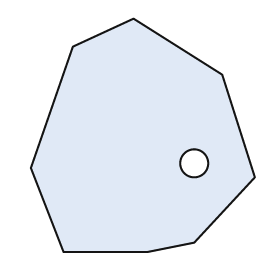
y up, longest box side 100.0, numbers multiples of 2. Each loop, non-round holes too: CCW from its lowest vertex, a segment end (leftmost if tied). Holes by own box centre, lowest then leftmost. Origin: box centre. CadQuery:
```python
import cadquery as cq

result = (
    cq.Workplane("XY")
    .moveTo(-34.0, -50.0)
    .lineTo(2.0, -50.0)
    .lineTo(22.0, -46.0)
    .lineTo(48.0, -18.0)
    .lineTo(34.0, 26.0)
    .lineTo(-4.0, 50.0)
    .lineTo(-30.0, 38.0)
    .lineTo(-48.0, -14.0)
    .close()
    .moveTo(22.0, -12.0)
    .circle(6.0)
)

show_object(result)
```